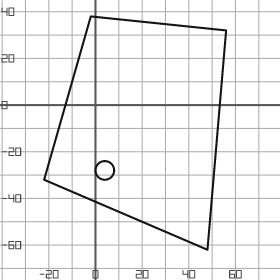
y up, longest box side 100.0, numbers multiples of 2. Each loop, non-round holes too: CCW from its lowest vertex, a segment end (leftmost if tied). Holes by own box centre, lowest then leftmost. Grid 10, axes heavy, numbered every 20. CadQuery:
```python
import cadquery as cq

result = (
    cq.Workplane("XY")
    .moveTo(48.0, -62.0)
    .lineTo(56.0, 32.0)
    .lineTo(-2.0, 38.0)
    .lineTo(-22.0, -32.0)
    .close()
    .moveTo(4.0, -28.0)
    .circle(4.0)
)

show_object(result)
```